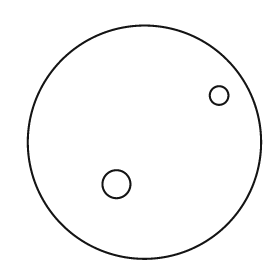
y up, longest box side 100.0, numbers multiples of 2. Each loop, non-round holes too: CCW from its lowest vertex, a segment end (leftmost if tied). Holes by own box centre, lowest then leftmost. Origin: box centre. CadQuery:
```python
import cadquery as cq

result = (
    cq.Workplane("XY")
    .moveTo(0.0, 0.0)
    .circle(50.0)
    .moveTo(-12.0, -18.0)
    .circle(6.0)
    .moveTo(32.0, 20.0)
    .circle(4.0)
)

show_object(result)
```